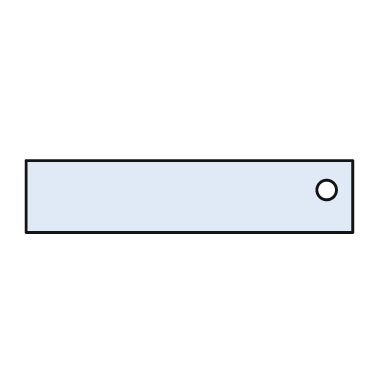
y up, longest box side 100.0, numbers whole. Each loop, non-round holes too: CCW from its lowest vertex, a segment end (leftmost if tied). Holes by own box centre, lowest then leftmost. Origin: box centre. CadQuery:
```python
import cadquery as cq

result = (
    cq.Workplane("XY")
    .moveTo(-50.0, -11.0)
    .lineTo(50.0, -11.0)
    .lineTo(50.0, 11.0)
    .lineTo(-50.0, 11.0)
    .close()
    .moveTo(42.0, 2.0)
    .circle(3.0)
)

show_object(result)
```